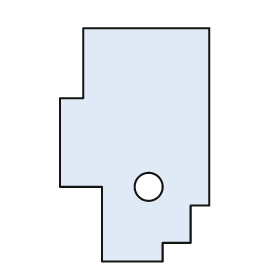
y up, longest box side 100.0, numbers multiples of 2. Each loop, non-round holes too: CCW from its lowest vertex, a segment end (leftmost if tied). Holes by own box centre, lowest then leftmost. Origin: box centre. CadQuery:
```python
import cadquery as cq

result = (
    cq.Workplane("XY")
    .moveTo(-14.0, -50.0)
    .lineTo(12.0, -50.0)
    .lineTo(12.0, -42.0)
    .lineTo(24.0, -42.0)
    .lineTo(24.0, -26.0)
    .lineTo(32.0, -26.0)
    .lineTo(32.0, 50.0)
    .lineTo(-22.0, 50.0)
    .lineTo(-22.0, 20.0)
    .lineTo(-32.0, 20.0)
    .lineTo(-32.0, -18.0)
    .lineTo(-14.0, -18.0)
    .close()
    .moveTo(6.0, -18.0)
    .circle(6.0)
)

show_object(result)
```